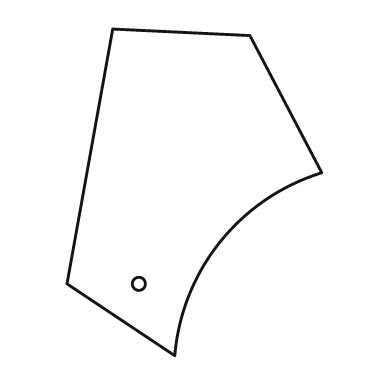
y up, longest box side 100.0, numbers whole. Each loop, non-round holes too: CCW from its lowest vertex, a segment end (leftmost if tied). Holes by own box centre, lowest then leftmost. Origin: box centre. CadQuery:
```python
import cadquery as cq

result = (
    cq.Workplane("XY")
    .moveTo(-6.0, -50.0)
    .threePointArc((8.0, -15.0), (39.0, 6.0))
    .lineTo(17.0, 48.0)
    .lineTo(-25.0, 50.0)
    .lineTo(-39.0, -28.0)
    .close()
    .moveTo(-17.0, -28.0)
    .circle(2.0)
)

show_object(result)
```